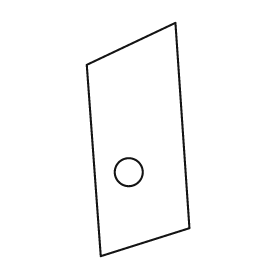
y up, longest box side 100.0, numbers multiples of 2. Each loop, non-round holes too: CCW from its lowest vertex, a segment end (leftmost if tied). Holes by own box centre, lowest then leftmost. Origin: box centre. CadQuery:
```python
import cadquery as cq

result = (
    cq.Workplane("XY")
    .moveTo(-16.0, -50.0)
    .lineTo(22.0, -38.0)
    .lineTo(16.0, 50.0)
    .lineTo(-22.0, 32.0)
    .close()
    .moveTo(-4.0, -14.0)
    .circle(6.0)
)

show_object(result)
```